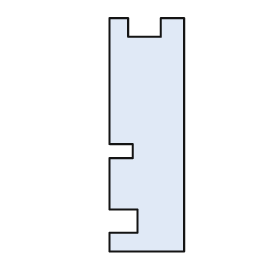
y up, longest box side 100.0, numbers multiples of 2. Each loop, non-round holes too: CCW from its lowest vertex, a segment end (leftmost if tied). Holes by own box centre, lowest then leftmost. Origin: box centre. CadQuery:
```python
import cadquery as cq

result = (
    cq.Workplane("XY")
    .moveTo(-16.0, -50.0)
    .lineTo(16.0, -50.0)
    .lineTo(16.0, 50.0)
    .lineTo(6.0, 50.0)
    .lineTo(6.0, 42.0)
    .lineTo(-8.0, 42.0)
    .lineTo(-8.0, 50.0)
    .lineTo(-16.0, 50.0)
    .lineTo(-16.0, -4.0)
    .lineTo(-6.0, -4.0)
    .lineTo(-6.0, -10.0)
    .lineTo(-16.0, -10.0)
    .lineTo(-16.0, -32.0)
    .lineTo(-4.0, -32.0)
    .lineTo(-4.0, -42.0)
    .lineTo(-16.0, -42.0)
    .close()
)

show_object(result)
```